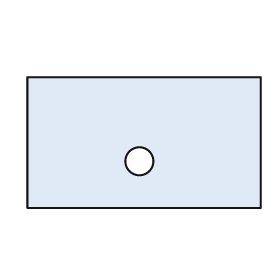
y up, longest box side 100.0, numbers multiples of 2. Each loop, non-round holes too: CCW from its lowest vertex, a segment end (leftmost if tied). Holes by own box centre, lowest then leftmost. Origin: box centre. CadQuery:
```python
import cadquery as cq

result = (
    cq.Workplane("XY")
    .moveTo(-50.0, -28.0)
    .lineTo(50.0, -28.0)
    .lineTo(50.0, 28.0)
    .lineTo(-50.0, 28.0)
    .close()
    .moveTo(-2.0, -8.0)
    .circle(6.0)
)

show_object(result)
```